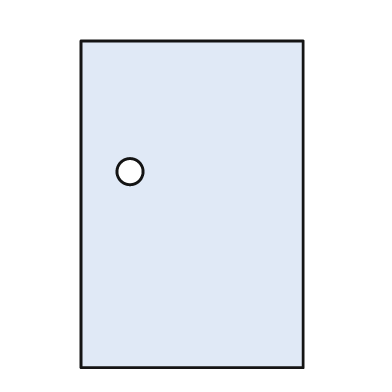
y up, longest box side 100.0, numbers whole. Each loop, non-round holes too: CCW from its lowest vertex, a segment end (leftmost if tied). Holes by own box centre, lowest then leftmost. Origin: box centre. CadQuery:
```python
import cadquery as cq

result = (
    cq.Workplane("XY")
    .moveTo(-34.0, -50.0)
    .lineTo(34.0, -50.0)
    .lineTo(34.0, 50.0)
    .lineTo(-34.0, 50.0)
    .close()
    .moveTo(-19.0, 10.0)
    .circle(4.0)
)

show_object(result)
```